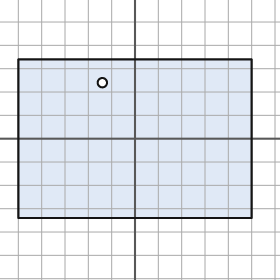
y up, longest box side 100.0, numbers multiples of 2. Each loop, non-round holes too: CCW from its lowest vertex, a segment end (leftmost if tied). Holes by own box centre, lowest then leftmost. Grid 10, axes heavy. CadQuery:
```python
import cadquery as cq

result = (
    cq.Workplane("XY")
    .moveTo(-50.0, -34.0)
    .lineTo(50.0, -34.0)
    .lineTo(50.0, 34.0)
    .lineTo(-50.0, 34.0)
    .close()
    .moveTo(-14.0, 24.0)
    .circle(2.0)
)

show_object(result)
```